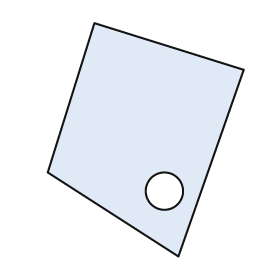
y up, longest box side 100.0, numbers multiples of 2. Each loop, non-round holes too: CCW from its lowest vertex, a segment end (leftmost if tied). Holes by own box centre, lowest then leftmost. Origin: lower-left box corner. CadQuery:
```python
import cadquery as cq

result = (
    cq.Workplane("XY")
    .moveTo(56.0, 0.0)
    .lineTo(84.0, 80.0)
    .lineTo(20.0, 100.0)
    .lineTo(0.0, 36.0)
    .close()
    .moveTo(50.0, 28.0)
    .circle(8.0)
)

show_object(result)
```